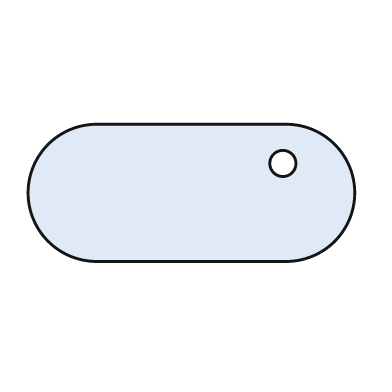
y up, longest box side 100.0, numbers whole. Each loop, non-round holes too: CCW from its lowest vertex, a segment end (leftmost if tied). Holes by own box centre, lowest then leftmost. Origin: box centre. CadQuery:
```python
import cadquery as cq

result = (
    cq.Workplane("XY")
    .moveTo(-29.0, -21.0)
    .lineTo(29.0, -21.0)
    .threePointArc((50.0, 0.0), (29.0, 21.0))
    .lineTo(-29.0, 21.0)
    .threePointArc((-50.0, 0.0), (-29.0, -21.0))
    .close()
    .moveTo(28.0, 9.0)
    .circle(4.0)
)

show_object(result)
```